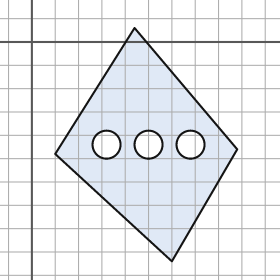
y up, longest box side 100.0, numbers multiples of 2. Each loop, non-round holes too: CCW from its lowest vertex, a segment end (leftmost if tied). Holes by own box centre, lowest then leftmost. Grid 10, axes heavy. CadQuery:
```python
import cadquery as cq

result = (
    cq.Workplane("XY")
    .moveTo(60.0, -94.0)
    .lineTo(88.0, -46.0)
    .lineTo(44.0, 6.0)
    .lineTo(10.0, -48.0)
    .close()
    .moveTo(32.0, -44.0)
    .circle(6.0)
    .moveTo(50.0, -44.0)
    .circle(6.0)
    .moveTo(68.0, -44.0)
    .circle(6.0)
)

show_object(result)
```